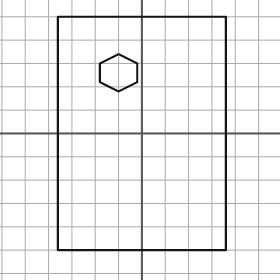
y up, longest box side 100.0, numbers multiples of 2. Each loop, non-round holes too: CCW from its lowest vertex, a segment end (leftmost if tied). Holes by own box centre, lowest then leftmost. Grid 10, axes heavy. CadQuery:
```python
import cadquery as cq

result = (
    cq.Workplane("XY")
    .moveTo(-36.0, -50.0)
    .lineTo(36.0, -50.0)
    .lineTo(36.0, 50.0)
    .lineTo(-36.0, 50.0)
    .close()
    .moveTo(-10.0, 18.0)
    .lineTo(-2.0, 22.0)
    .lineTo(-2.0, 30.0)
    .lineTo(-10.0, 34.0)
    .lineTo(-18.0, 30.0)
    .lineTo(-18.0, 22.0)
    .close()
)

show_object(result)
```